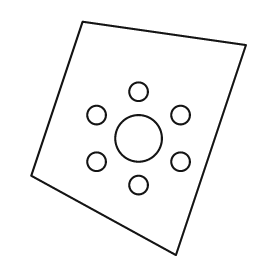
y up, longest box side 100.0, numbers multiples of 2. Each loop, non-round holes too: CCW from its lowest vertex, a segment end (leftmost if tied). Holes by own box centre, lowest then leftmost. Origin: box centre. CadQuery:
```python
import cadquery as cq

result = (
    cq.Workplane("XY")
    .moveTo(16.0, -50.0)
    .lineTo(46.0, 40.0)
    .lineTo(-24.0, 50.0)
    .lineTo(-46.0, -16.0)
    .close()
    .moveTo(0.0, -20.0)
    .circle(4.0)
    .moveTo(-18.0, -10.0)
    .circle(4.0)
    .moveTo(18.0, -10.0)
    .circle(4.0)
    .moveTo(0.0, 0.0)
    .circle(10.0)
    .moveTo(-18.0, 10.0)
    .circle(4.0)
    .moveTo(18.0, 10.0)
    .circle(4.0)
    .moveTo(0.0, 20.0)
    .circle(4.0)
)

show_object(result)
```